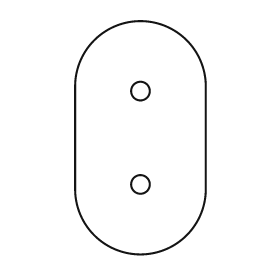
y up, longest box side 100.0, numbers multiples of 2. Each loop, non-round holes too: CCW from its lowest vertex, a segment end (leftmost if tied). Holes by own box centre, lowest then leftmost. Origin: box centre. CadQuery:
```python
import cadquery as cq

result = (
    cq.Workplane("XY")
    .moveTo(-28.0, -22.0)
    .threePointArc((0.0, -50.0), (28.0, -22.0))
    .lineTo(28.0, 22.0)
    .threePointArc((0.0, 50.0), (-28.0, 22.0))
    .close()
    .moveTo(0.0, -20.0)
    .circle(4.0)
    .moveTo(0.0, 20.0)
    .circle(4.0)
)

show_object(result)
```